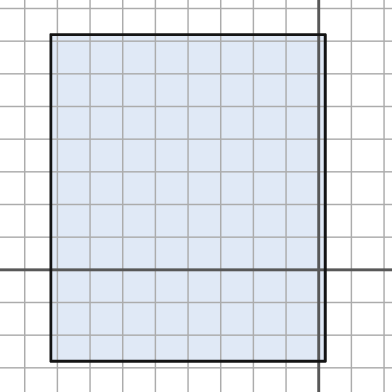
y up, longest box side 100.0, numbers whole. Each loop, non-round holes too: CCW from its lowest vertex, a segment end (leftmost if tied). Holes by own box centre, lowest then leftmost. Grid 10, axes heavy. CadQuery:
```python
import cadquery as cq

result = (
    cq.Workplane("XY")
    .moveTo(-82.0, -28.0)
    .lineTo(2.0, -28.0)
    .lineTo(2.0, 72.0)
    .lineTo(-82.0, 72.0)
    .close()
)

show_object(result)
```